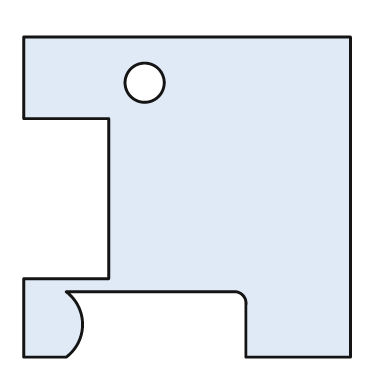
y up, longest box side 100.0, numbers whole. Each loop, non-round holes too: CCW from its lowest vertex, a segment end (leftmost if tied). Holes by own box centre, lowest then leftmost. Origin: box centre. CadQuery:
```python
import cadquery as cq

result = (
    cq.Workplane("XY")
    .moveTo(-50.0, -49.0)
    .lineTo(-37.0, -49.0)
    .threePointArc((-32.0, -39.0), (-37.0, -29.0))
    .lineTo(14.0, -29.0)
    .threePointArc((17.0, -30.0), (18.0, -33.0))
    .lineTo(18.0, -49.0)
    .lineTo(50.0, -49.0)
    .lineTo(50.0, 49.0)
    .lineTo(-50.0, 49.0)
    .lineTo(-50.0, 24.0)
    .lineTo(-24.0, 24.0)
    .lineTo(-24.0, -25.0)
    .lineTo(-50.0, -25.0)
    .close()
    .moveTo(-13.0, 35.0)
    .circle(6.0)
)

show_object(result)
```